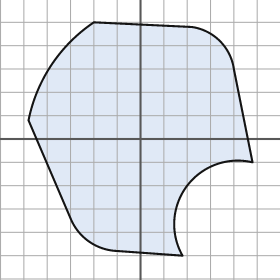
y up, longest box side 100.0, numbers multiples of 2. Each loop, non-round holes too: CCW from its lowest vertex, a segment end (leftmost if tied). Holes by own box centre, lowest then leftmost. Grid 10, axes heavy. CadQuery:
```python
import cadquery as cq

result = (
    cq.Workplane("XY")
    .moveTo(18.0, -50.0)
    .threePointArc((20.0, -20.0), (48.0, -10.0))
    .lineTo(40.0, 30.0)
    .threePointArc((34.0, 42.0), (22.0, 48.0))
    .lineTo(-20.0, 50.0)
    .threePointArc((-38.0, 32.0), (-48.0, 8.0))
    .lineTo(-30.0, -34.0)
    .threePointArc((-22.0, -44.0), (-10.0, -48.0))
    .close()
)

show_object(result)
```